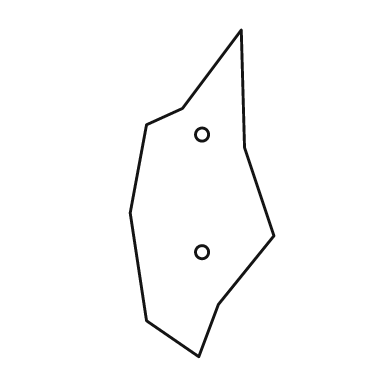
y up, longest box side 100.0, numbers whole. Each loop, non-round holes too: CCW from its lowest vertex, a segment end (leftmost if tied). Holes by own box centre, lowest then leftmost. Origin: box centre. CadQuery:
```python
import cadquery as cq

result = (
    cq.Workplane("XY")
    .moveTo(-1.0, -50.0)
    .lineTo(5.0, -34.0)
    .lineTo(22.0, -13.0)
    .lineTo(13.0, 14.0)
    .lineTo(12.0, 50.0)
    .lineTo(-6.0, 26.0)
    .lineTo(-17.0, 21.0)
    .lineTo(-22.0, -6.0)
    .lineTo(-17.0, -39.0)
    .close()
    .moveTo(0.0, -18.0)
    .circle(2.0)
    .moveTo(0.0, 18.0)
    .circle(2.0)
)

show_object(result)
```